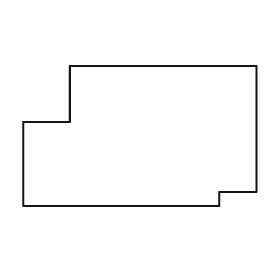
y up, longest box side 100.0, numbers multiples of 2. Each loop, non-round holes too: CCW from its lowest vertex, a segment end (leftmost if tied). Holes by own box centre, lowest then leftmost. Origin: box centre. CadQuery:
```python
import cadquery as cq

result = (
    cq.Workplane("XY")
    .moveTo(-50.0, -30.0)
    .lineTo(34.0, -30.0)
    .lineTo(34.0, -24.0)
    .lineTo(50.0, -24.0)
    .lineTo(50.0, 30.0)
    .lineTo(-30.0, 30.0)
    .lineTo(-30.0, 6.0)
    .lineTo(-50.0, 6.0)
    .close()
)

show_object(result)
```